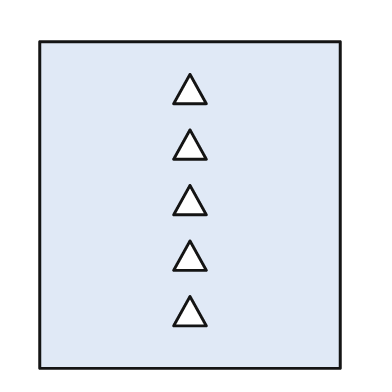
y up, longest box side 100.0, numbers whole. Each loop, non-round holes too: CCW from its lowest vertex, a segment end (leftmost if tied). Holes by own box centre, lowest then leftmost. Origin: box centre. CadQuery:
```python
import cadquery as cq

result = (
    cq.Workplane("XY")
    .moveTo(-46.0, -50.0)
    .lineTo(46.0, -50.0)
    .lineTo(46.0, 50.0)
    .lineTo(-46.0, 50.0)
    .close()
    .moveTo(-5.0, -37.0)
    .lineTo(5.0, -37.0)
    .lineTo(0.0, -28.0)
    .close()
    .moveTo(-5.0, -20.0)
    .lineTo(5.0, -20.0)
    .lineTo(0.0, -11.0)
    .close()
    .moveTo(-5.0, -3.0)
    .lineTo(5.0, -3.0)
    .lineTo(0.0, 6.0)
    .close()
    .moveTo(-5.0, 14.0)
    .lineTo(5.0, 14.0)
    .lineTo(0.0, 23.0)
    .close()
    .moveTo(-5.0, 31.0)
    .lineTo(5.0, 31.0)
    .lineTo(0.0, 40.0)
    .close()
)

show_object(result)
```